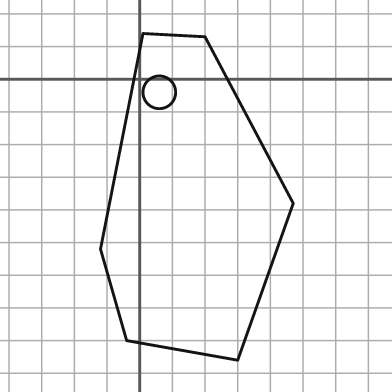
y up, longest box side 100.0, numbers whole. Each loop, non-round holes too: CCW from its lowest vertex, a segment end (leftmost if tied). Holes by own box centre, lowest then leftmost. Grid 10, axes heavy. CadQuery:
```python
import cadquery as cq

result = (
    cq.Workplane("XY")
    .moveTo(30.0, -86.0)
    .lineTo(47.0, -38.0)
    .lineTo(20.0, 13.0)
    .lineTo(1.0, 14.0)
    .lineTo(-12.0, -52.0)
    .lineTo(-4.0, -80.0)
    .close()
    .moveTo(6.0, -4.0)
    .circle(5.0)
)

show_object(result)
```